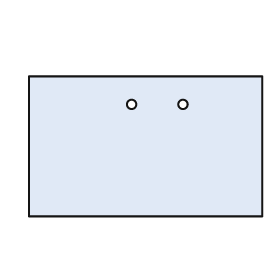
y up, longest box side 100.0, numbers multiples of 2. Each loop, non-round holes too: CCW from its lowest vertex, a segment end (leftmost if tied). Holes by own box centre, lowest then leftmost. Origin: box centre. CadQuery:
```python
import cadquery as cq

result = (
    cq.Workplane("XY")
    .moveTo(-50.0, -30.0)
    .lineTo(50.0, -30.0)
    .lineTo(50.0, 30.0)
    .lineTo(-50.0, 30.0)
    .close()
    .moveTo(-6.0, 18.0)
    .circle(2.0)
    .moveTo(16.0, 18.0)
    .circle(2.0)
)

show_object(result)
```